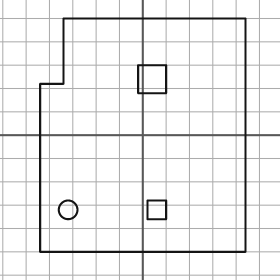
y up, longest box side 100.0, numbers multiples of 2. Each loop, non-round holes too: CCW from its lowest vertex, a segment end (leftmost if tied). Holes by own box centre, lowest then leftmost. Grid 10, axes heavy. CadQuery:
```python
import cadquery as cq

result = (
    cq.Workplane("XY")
    .moveTo(-44.0, -50.0)
    .lineTo(44.0, -50.0)
    .lineTo(44.0, 50.0)
    .lineTo(-34.0, 50.0)
    .lineTo(-34.0, 22.0)
    .lineTo(-44.0, 22.0)
    .close()
    .moveTo(-32.0, -32.0)
    .circle(4.0)
    .moveTo(2.0, -36.0)
    .lineTo(10.0, -36.0)
    .lineTo(10.0, -28.0)
    .lineTo(2.0, -28.0)
    .close()
    .moveTo(-2.0, 18.0)
    .lineTo(10.0, 18.0)
    .lineTo(10.0, 30.0)
    .lineTo(-2.0, 30.0)
    .close()
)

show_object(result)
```